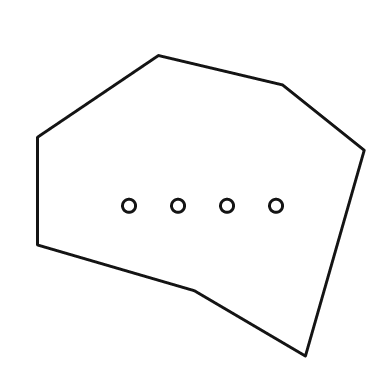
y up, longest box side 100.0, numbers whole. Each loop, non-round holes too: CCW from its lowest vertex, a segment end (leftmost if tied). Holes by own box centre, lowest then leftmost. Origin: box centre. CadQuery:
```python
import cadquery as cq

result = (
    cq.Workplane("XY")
    .moveTo(32.0, -46.0)
    .lineTo(50.0, 17.0)
    .lineTo(25.0, 37.0)
    .lineTo(-13.0, 46.0)
    .lineTo(-50.0, 21.0)
    .lineTo(-50.0, -12.0)
    .lineTo(-2.0, -26.0)
    .close()
    .moveTo(-22.0, 0.0)
    .circle(2.0)
    .moveTo(-7.0, 0.0)
    .circle(2.0)
    .moveTo(8.0, 0.0)
    .circle(2.0)
    .moveTo(23.0, 0.0)
    .circle(2.0)
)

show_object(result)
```